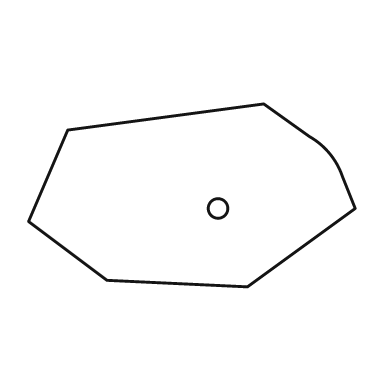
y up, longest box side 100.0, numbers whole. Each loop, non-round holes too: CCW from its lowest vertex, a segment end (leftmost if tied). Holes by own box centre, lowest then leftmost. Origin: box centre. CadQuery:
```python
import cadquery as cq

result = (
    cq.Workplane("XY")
    .moveTo(17.0, -28.0)
    .lineTo(50.0, -4.0)
    .lineTo(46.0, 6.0)
    .threePointArc((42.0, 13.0), (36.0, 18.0))
    .lineTo(22.0, 28.0)
    .lineTo(-38.0, 20.0)
    .lineTo(-50.0, -8.0)
    .lineTo(-26.0, -26.0)
    .close()
    .moveTo(8.0, -4.0)
    .circle(3.0)
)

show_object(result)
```